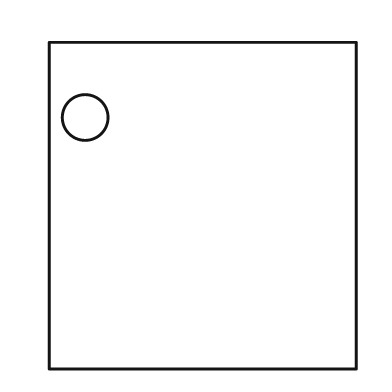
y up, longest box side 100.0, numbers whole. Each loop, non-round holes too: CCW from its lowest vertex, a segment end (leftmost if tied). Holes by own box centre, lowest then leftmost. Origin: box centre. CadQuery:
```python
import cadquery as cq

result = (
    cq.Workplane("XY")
    .moveTo(-47.0, -50.0)
    .lineTo(47.0, -50.0)
    .lineTo(47.0, 50.0)
    .lineTo(-47.0, 50.0)
    .close()
    .moveTo(-36.0, 27.0)
    .circle(7.0)
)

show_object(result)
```